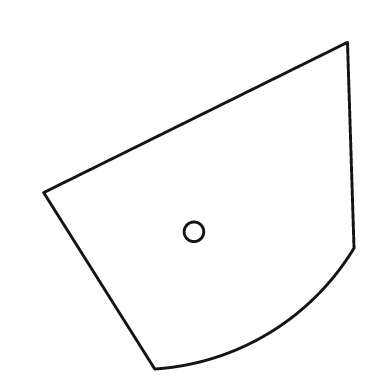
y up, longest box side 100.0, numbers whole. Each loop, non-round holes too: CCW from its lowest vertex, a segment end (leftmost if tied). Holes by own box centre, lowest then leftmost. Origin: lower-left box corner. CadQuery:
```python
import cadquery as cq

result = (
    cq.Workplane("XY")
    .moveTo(34.0, 0.0)
    .threePointArc((69.0, 11.0), (95.0, 37.0))
    .lineTo(93.0, 100.0)
    .lineTo(0.0, 54.0)
    .close()
    .moveTo(46.0, 42.0)
    .circle(3.0)
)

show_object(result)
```